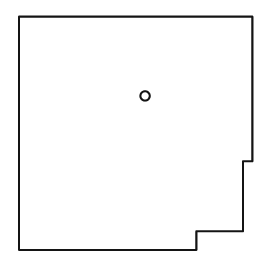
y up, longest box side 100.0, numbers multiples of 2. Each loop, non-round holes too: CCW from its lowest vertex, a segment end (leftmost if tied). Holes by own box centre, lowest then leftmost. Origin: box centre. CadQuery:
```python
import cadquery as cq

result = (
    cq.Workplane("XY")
    .moveTo(-50.0, -50.0)
    .lineTo(26.0, -50.0)
    .lineTo(26.0, -42.0)
    .lineTo(46.0, -42.0)
    .lineTo(46.0, -12.0)
    .lineTo(50.0, -12.0)
    .lineTo(50.0, 50.0)
    .lineTo(-50.0, 50.0)
    .close()
    .moveTo(4.0, 16.0)
    .circle(2.0)
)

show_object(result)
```